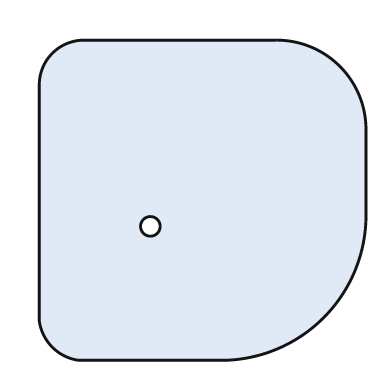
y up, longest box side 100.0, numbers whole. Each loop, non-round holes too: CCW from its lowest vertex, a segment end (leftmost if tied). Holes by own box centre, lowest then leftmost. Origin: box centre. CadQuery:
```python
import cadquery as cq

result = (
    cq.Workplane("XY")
    .moveTo(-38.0, -49.0)
    .lineTo(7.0, -49.0)
    .threePointArc((37.0, -36.0), (50.0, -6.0))
    .lineTo(50.0, 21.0)
    .threePointArc((42.0, 41.0), (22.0, 49.0))
    .lineTo(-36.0, 49.0)
    .threePointArc((-46.0, 45.0), (-50.0, 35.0))
    .lineTo(-50.0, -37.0)
    .threePointArc((-46.0, -45.0), (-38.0, -49.0))
    .close()
    .moveTo(-16.0, -8.0)
    .circle(3.0)
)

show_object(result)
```